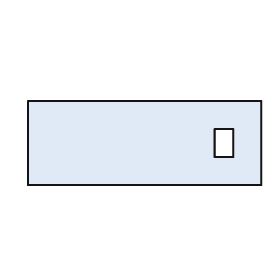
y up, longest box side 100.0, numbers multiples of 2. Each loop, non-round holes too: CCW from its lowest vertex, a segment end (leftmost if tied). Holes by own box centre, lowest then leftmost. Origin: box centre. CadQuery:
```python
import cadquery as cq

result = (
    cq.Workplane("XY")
    .moveTo(-50.0, -18.0)
    .lineTo(50.0, -18.0)
    .lineTo(50.0, 18.0)
    .lineTo(-50.0, 18.0)
    .close()
    .moveTo(30.0, -6.0)
    .lineTo(38.0, -6.0)
    .lineTo(38.0, 6.0)
    .lineTo(30.0, 6.0)
    .close()
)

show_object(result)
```